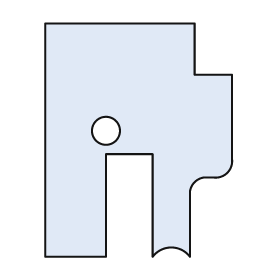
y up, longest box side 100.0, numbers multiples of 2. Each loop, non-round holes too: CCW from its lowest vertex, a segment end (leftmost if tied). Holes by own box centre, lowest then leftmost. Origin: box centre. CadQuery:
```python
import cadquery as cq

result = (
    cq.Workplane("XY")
    .moveTo(-40.0, -50.0)
    .lineTo(-14.0, -50.0)
    .lineTo(-14.0, -6.0)
    .lineTo(6.0, -6.0)
    .lineTo(6.0, -50.0)
    .threePointArc((14.0, -46.0), (22.0, -50.0))
    .lineTo(22.0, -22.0)
    .threePointArc((24.0, -18.0), (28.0, -16.0))
    .lineTo(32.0, -16.0)
    .threePointArc((38.0, -14.0), (40.0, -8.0))
    .lineTo(40.0, 28.0)
    .lineTo(24.0, 28.0)
    .lineTo(24.0, 50.0)
    .lineTo(-40.0, 50.0)
    .close()
    .moveTo(-14.0, 4.0)
    .circle(6.0)
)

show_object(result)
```